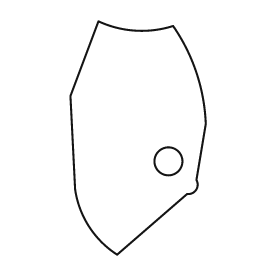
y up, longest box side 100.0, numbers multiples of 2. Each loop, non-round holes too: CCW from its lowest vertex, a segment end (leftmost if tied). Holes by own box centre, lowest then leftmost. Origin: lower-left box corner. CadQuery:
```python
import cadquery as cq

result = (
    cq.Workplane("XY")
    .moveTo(20.0, 0.0)
    .lineTo(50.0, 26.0)
    .threePointArc((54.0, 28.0), (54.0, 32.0))
    .lineTo(58.0, 56.0)
    .threePointArc((54.0, 78.0), (44.0, 98.0))
    .threePointArc((28.0, 96.0), (12.0, 100.0))
    .lineTo(0.0, 68.0)
    .lineTo(2.0, 28.0)
    .threePointArc((8.0, 12.0), (20.0, 0.0))
    .close()
    .moveTo(42.0, 40.0)
    .circle(6.0)
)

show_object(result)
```